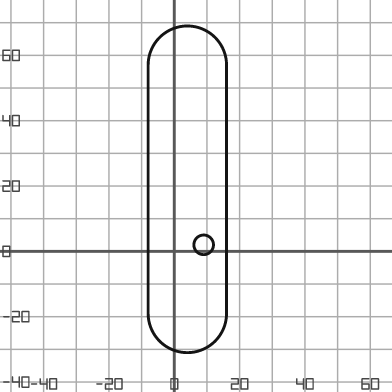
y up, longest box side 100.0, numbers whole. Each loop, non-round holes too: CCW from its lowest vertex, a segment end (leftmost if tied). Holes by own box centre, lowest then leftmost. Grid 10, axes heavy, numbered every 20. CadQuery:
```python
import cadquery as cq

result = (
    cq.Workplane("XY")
    .moveTo(-8.0, -19.0)
    .threePointArc((4.0, -31.0), (16.0, -19.0))
    .lineTo(16.0, 57.0)
    .threePointArc((4.0, 69.0), (-8.0, 57.0))
    .close()
    .moveTo(9.0, 2.0)
    .circle(3.0)
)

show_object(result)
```